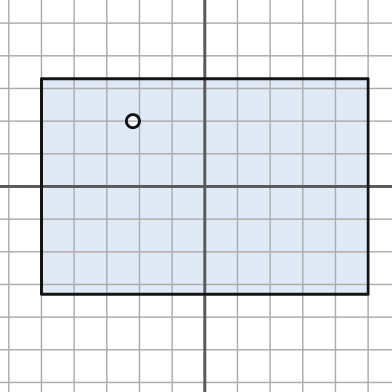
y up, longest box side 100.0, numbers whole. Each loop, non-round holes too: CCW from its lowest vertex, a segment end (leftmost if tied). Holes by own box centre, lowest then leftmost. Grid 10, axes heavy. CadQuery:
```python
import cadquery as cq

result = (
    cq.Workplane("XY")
    .moveTo(-50.0, -33.0)
    .lineTo(50.0, -33.0)
    .lineTo(50.0, 33.0)
    .lineTo(-50.0, 33.0)
    .close()
    .moveTo(-22.0, 20.0)
    .circle(2.0)
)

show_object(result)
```